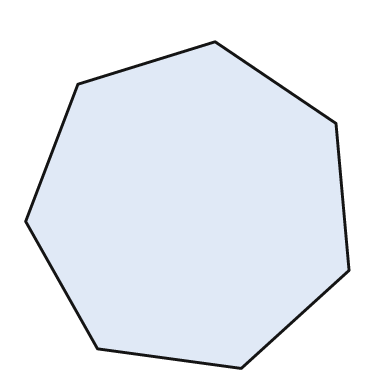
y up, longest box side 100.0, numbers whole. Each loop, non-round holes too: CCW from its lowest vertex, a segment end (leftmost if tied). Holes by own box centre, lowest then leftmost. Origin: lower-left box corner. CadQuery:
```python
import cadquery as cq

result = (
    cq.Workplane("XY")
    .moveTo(66.0, 0.0)
    .lineTo(99.0, 30.0)
    .lineTo(95.0, 75.0)
    .lineTo(58.0, 100.0)
    .lineTo(16.0, 87.0)
    .lineTo(0.0, 45.0)
    .lineTo(22.0, 6.0)
    .close()
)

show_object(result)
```